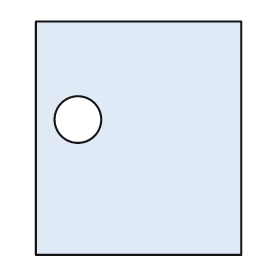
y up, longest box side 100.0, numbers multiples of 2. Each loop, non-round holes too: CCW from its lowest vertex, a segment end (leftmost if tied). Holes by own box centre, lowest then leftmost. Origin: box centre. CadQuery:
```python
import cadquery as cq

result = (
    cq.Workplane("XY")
    .moveTo(-44.0, -50.0)
    .lineTo(44.0, -50.0)
    .lineTo(44.0, 50.0)
    .lineTo(-44.0, 50.0)
    .close()
    .moveTo(-26.0, 8.0)
    .circle(10.0)
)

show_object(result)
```